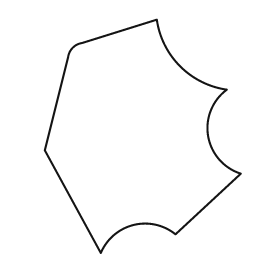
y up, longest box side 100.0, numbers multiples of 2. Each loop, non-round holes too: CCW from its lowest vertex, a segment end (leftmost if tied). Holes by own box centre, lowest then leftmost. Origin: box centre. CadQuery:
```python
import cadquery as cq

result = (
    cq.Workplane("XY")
    .moveTo(-18.0, -50.0)
    .threePointArc((-4.0, -38.0), (14.0, -42.0))
    .lineTo(42.0, -16.0)
    .threePointArc((28.0, 0.0), (36.0, 20.0))
    .threePointArc((16.0, 30.0), (6.0, 50.0))
    .lineTo(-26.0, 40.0)
    .threePointArc((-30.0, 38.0), (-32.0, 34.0))
    .lineTo(-42.0, -6.0)
    .close()
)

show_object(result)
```